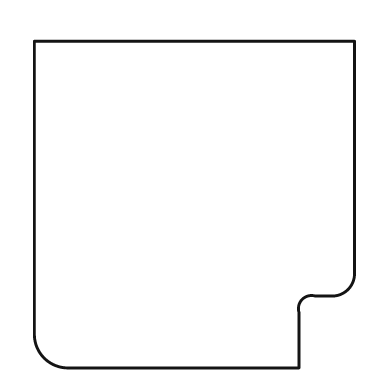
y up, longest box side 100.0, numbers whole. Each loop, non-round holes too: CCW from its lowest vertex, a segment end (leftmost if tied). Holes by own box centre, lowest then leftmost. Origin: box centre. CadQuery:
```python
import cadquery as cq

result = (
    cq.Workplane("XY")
    .moveTo(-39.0, -50.0)
    .lineTo(32.0, -50.0)
    .lineTo(32.0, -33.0)
    .threePointArc((33.0, -29.0), (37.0, -28.0))
    .lineTo(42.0, -28.0)
    .threePointArc((47.0, -26.0), (49.0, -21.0))
    .lineTo(49.0, 50.0)
    .lineTo(-49.0, 50.0)
    .lineTo(-49.0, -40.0)
    .threePointArc((-46.0, -47.0), (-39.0, -50.0))
    .close()
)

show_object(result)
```